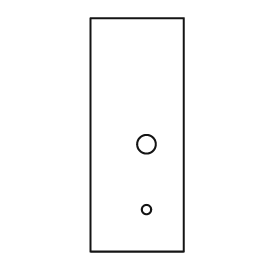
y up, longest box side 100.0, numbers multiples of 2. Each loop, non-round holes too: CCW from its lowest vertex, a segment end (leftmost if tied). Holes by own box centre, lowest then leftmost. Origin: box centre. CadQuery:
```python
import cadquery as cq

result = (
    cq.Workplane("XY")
    .moveTo(-20.0, -50.0)
    .lineTo(20.0, -50.0)
    .lineTo(20.0, 50.0)
    .lineTo(-20.0, 50.0)
    .close()
    .moveTo(4.0, -32.0)
    .circle(2.0)
    .moveTo(4.0, -4.0)
    .circle(4.0)
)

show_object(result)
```